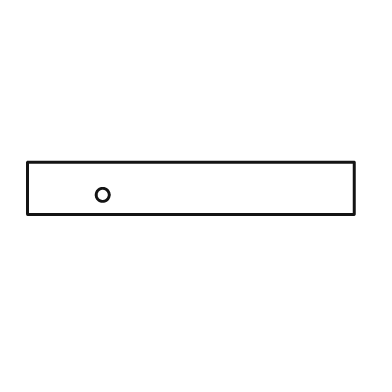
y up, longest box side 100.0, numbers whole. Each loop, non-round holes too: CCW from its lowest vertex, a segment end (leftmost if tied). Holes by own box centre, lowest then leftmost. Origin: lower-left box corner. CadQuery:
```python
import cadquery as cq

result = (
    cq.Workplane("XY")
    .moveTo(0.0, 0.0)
    .lineTo(100.0, 0.0)
    .lineTo(100.0, 16.0)
    .lineTo(0.0, 16.0)
    .close()
    .moveTo(23.0, 6.0)
    .circle(2.0)
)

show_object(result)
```